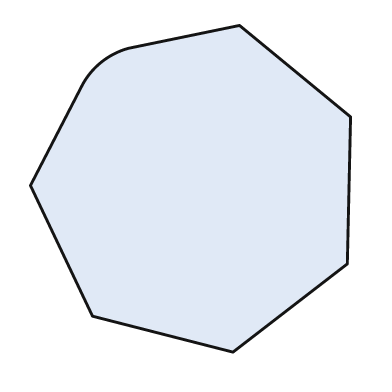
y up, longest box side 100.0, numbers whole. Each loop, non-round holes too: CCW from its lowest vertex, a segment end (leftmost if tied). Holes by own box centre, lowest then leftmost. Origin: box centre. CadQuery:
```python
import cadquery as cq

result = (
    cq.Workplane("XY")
    .moveTo(13.0, -50.0)
    .lineTo(48.0, -23.0)
    .lineTo(49.0, 22.0)
    .lineTo(15.0, 50.0)
    .lineTo(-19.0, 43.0)
    .threePointArc((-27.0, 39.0), (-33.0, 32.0))
    .lineTo(-49.0, 1.0)
    .lineTo(-30.0, -39.0)
    .close()
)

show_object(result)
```